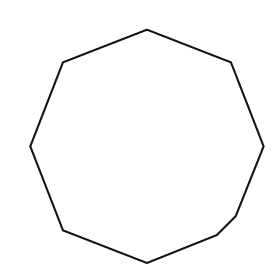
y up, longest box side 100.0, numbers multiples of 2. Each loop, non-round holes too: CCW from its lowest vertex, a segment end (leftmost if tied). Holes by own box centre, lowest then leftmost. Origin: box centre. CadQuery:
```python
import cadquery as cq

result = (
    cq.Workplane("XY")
    .moveTo(0.0, -50.0)
    .lineTo(30.0, -38.0)
    .lineTo(38.0, -30.0)
    .lineTo(50.0, 0.0)
    .lineTo(36.0, 36.0)
    .lineTo(0.0, 50.0)
    .lineTo(-36.0, 36.0)
    .lineTo(-50.0, 0.0)
    .lineTo(-36.0, -36.0)
    .close()
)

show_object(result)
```